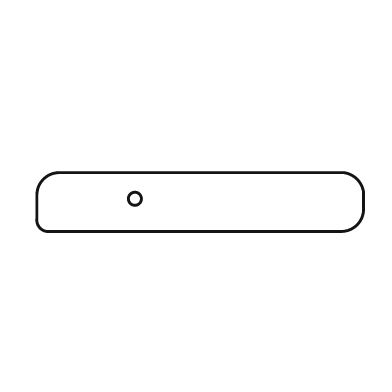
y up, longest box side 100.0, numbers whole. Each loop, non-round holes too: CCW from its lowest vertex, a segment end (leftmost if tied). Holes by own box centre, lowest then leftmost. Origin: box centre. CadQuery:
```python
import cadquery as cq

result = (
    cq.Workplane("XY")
    .moveTo(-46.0, -9.0)
    .lineTo(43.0, -9.0)
    .threePointArc((48.0, -7.0), (50.0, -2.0))
    .lineTo(50.0, 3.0)
    .threePointArc((48.0, 7.0), (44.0, 9.0))
    .lineTo(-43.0, 9.0)
    .threePointArc((-48.0, 7.0), (-50.0, 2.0))
    .lineTo(-50.0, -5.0)
    .threePointArc((-49.0, -8.0), (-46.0, -9.0))
    .close()
    .moveTo(-20.0, 1.0)
    .circle(2.0)
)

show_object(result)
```